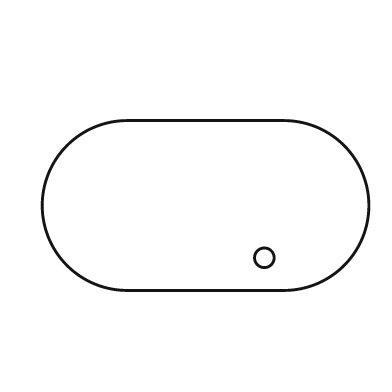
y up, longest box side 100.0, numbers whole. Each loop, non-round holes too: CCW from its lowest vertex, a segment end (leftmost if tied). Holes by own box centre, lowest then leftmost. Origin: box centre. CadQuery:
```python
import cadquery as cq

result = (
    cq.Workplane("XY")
    .moveTo(-24.0, -26.0)
    .lineTo(24.0, -26.0)
    .threePointArc((50.0, 0.0), (24.0, 26.0))
    .lineTo(-24.0, 26.0)
    .threePointArc((-50.0, 0.0), (-24.0, -26.0))
    .close()
    .moveTo(18.0, -16.0)
    .circle(3.0)
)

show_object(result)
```